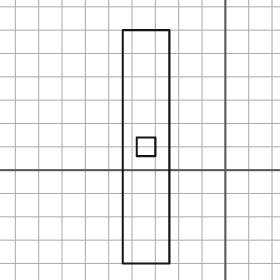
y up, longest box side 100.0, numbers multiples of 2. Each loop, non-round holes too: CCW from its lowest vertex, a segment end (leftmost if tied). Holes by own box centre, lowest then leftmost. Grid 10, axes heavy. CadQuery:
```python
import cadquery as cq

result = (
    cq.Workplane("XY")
    .moveTo(-44.0, -40.0)
    .lineTo(-24.0, -40.0)
    .lineTo(-24.0, 60.0)
    .lineTo(-44.0, 60.0)
    .close()
    .moveTo(-38.0, 6.0)
    .lineTo(-30.0, 6.0)
    .lineTo(-30.0, 14.0)
    .lineTo(-38.0, 14.0)
    .close()
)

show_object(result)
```